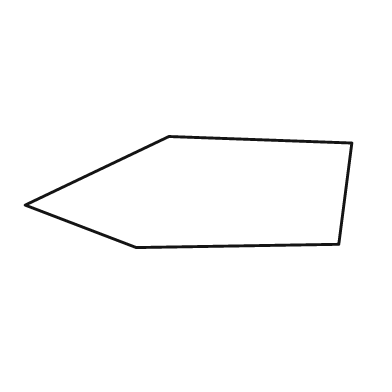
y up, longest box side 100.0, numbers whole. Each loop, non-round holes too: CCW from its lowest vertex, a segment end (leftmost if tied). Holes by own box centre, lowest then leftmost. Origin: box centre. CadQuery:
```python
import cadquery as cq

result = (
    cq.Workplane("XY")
    .moveTo(-16.0, -17.0)
    .lineTo(46.0, -16.0)
    .lineTo(50.0, 15.0)
    .lineTo(-6.0, 17.0)
    .lineTo(-50.0, -4.0)
    .close()
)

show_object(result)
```